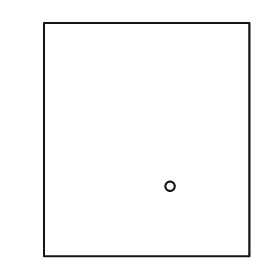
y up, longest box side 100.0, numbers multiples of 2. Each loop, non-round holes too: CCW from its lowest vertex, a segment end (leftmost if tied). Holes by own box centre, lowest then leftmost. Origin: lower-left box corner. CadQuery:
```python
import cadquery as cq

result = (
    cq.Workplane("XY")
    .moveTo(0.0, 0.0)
    .lineTo(88.0, 0.0)
    .lineTo(88.0, 100.0)
    .lineTo(0.0, 100.0)
    .close()
    .moveTo(54.0, 30.0)
    .circle(2.0)
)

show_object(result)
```